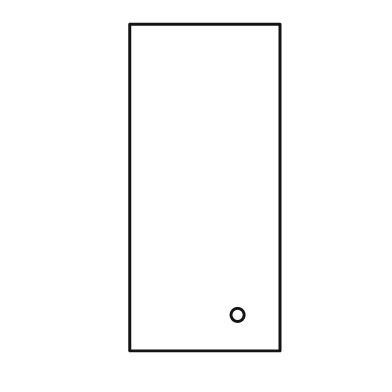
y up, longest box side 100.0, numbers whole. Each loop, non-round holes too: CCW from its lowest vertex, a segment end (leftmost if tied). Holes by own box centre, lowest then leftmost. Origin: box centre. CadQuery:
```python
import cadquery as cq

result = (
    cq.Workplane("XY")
    .moveTo(-23.0, -50.0)
    .lineTo(23.0, -50.0)
    .lineTo(23.0, 50.0)
    .lineTo(-23.0, 50.0)
    .close()
    .moveTo(10.0, -39.0)
    .circle(2.0)
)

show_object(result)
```